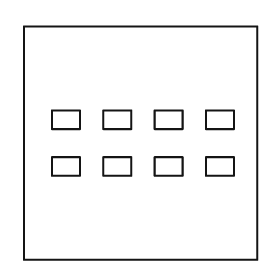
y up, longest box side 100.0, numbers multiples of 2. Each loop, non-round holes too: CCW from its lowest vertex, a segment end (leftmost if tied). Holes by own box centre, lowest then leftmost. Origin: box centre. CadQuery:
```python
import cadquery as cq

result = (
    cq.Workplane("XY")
    .moveTo(-50.0, -50.0)
    .lineTo(50.0, -50.0)
    .lineTo(50.0, 50.0)
    .lineTo(-50.0, 50.0)
    .close()
    .moveTo(-38.0, -14.0)
    .lineTo(-26.0, -14.0)
    .lineTo(-26.0, -6.0)
    .lineTo(-38.0, -6.0)
    .close()
    .moveTo(-16.0, -14.0)
    .lineTo(-4.0, -14.0)
    .lineTo(-4.0, -6.0)
    .lineTo(-16.0, -6.0)
    .close()
    .moveTo(6.0, -14.0)
    .lineTo(18.0, -14.0)
    .lineTo(18.0, -6.0)
    .lineTo(6.0, -6.0)
    .close()
    .moveTo(28.0, -14.0)
    .lineTo(40.0, -14.0)
    .lineTo(40.0, -6.0)
    .lineTo(28.0, -6.0)
    .close()
    .moveTo(-38.0, 6.0)
    .lineTo(-26.0, 6.0)
    .lineTo(-26.0, 14.0)
    .lineTo(-38.0, 14.0)
    .close()
    .moveTo(-16.0, 6.0)
    .lineTo(-4.0, 6.0)
    .lineTo(-4.0, 14.0)
    .lineTo(-16.0, 14.0)
    .close()
    .moveTo(6.0, 6.0)
    .lineTo(18.0, 6.0)
    .lineTo(18.0, 14.0)
    .lineTo(6.0, 14.0)
    .close()
    .moveTo(28.0, 6.0)
    .lineTo(40.0, 6.0)
    .lineTo(40.0, 14.0)
    .lineTo(28.0, 14.0)
    .close()
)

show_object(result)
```